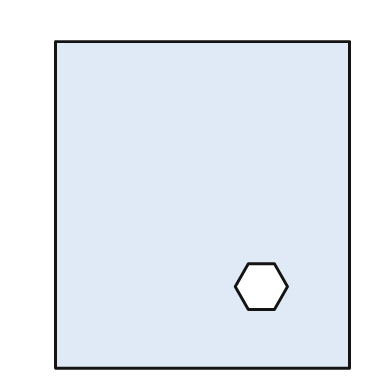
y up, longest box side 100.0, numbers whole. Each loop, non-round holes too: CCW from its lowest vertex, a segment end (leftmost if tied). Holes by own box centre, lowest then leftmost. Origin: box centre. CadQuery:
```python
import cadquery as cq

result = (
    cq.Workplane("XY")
    .moveTo(-45.0, -50.0)
    .lineTo(45.0, -50.0)
    .lineTo(45.0, 50.0)
    .lineTo(-45.0, 50.0)
    .close()
    .moveTo(14.0, -32.0)
    .lineTo(22.0, -32.0)
    .lineTo(26.0, -25.0)
    .lineTo(22.0, -18.0)
    .lineTo(14.0, -18.0)
    .lineTo(10.0, -25.0)
    .close()
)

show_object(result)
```